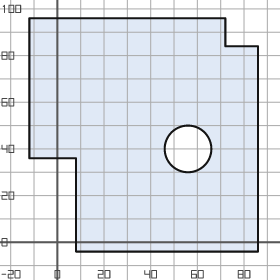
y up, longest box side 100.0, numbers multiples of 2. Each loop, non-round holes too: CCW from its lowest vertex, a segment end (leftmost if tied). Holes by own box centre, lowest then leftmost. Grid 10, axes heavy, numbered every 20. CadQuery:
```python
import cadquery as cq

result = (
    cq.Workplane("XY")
    .moveTo(8.0, -4.0)
    .lineTo(86.0, -4.0)
    .lineTo(86.0, 84.0)
    .lineTo(72.0, 84.0)
    .lineTo(72.0, 96.0)
    .lineTo(-12.0, 96.0)
    .lineTo(-12.0, 36.0)
    .lineTo(8.0, 36.0)
    .close()
    .moveTo(56.0, 40.0)
    .circle(10.0)
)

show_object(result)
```